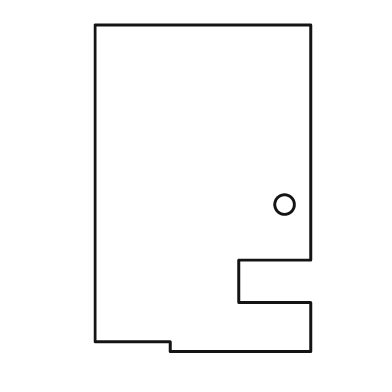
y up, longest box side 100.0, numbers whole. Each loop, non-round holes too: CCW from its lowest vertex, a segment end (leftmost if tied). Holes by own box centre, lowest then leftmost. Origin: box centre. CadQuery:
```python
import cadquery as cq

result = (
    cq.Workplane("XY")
    .moveTo(-10.0, -50.0)
    .lineTo(33.0, -50.0)
    .lineTo(33.0, -35.0)
    .lineTo(11.0, -35.0)
    .lineTo(11.0, -22.0)
    .lineTo(33.0, -22.0)
    .lineTo(33.0, 50.0)
    .lineTo(-33.0, 50.0)
    .lineTo(-33.0, -47.0)
    .lineTo(-10.0, -47.0)
    .close()
    .moveTo(25.0, -5.0)
    .circle(3.0)
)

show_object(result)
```